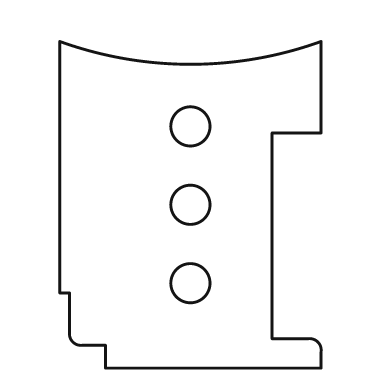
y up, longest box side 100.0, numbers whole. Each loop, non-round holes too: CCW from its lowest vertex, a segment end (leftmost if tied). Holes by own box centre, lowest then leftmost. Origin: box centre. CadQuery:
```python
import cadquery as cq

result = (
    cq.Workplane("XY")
    .moveTo(-26.0, -50.0)
    .lineTo(40.0, -50.0)
    .lineTo(40.0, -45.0)
    .threePointArc((39.0, -42.0), (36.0, -41.0))
    .lineTo(25.0, -41.0)
    .lineTo(25.0, 22.0)
    .lineTo(40.0, 22.0)
    .lineTo(40.0, 50.0)
    .threePointArc((0.0, 43.0), (-40.0, 50.0))
    .lineTo(-40.0, -27.0)
    .lineTo(-37.0, -27.0)
    .lineTo(-37.0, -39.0)
    .threePointArc((-36.0, -42.0), (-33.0, -43.0))
    .lineTo(-26.0, -43.0)
    .close()
    .moveTo(0.0, -24.0)
    .circle(6.0)
    .moveTo(0.0, 0.0)
    .circle(6.0)
    .moveTo(0.0, 24.0)
    .circle(6.0)
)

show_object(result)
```